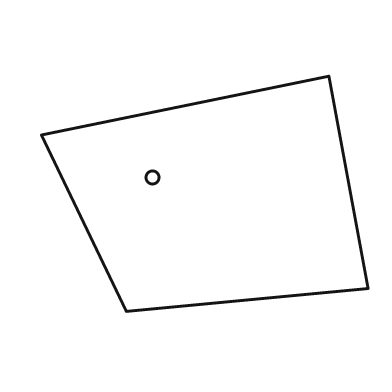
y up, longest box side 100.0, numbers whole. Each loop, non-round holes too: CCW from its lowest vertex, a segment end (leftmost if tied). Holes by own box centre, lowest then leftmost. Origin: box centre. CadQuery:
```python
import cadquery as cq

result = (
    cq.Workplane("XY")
    .moveTo(-24.0, -36.0)
    .lineTo(50.0, -29.0)
    .lineTo(38.0, 36.0)
    .lineTo(-50.0, 18.0)
    .close()
    .moveTo(-16.0, 5.0)
    .circle(2.0)
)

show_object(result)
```